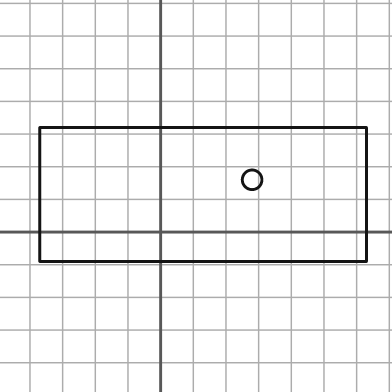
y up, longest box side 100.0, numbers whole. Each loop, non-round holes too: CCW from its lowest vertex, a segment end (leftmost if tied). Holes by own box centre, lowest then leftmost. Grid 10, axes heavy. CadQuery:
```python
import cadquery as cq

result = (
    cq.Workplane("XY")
    .moveTo(-37.0, -9.0)
    .lineTo(63.0, -9.0)
    .lineTo(63.0, 32.0)
    .lineTo(-37.0, 32.0)
    .close()
    .moveTo(28.0, 16.0)
    .circle(3.0)
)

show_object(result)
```